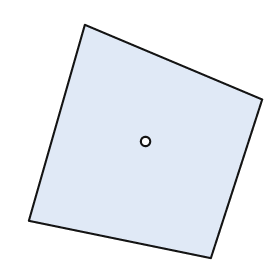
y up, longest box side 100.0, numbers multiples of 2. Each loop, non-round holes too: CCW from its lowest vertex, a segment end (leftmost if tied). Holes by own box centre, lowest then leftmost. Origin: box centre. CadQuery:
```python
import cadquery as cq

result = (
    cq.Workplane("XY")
    .moveTo(28.0, -50.0)
    .lineTo(50.0, 18.0)
    .lineTo(-26.0, 50.0)
    .lineTo(-50.0, -34.0)
    .close()
    .moveTo(0.0, 0.0)
    .circle(2.0)
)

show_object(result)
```